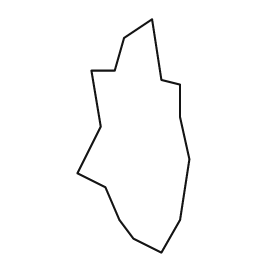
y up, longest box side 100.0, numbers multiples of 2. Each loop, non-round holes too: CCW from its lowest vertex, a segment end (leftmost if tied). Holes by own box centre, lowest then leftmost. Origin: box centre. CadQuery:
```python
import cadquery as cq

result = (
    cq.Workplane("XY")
    .moveTo(12.0, -50.0)
    .lineTo(20.0, -36.0)
    .lineTo(24.0, -10.0)
    .lineTo(20.0, 8.0)
    .lineTo(20.0, 22.0)
    .lineTo(12.0, 24.0)
    .lineTo(8.0, 50.0)
    .lineTo(-4.0, 42.0)
    .lineTo(-8.0, 28.0)
    .lineTo(-18.0, 28.0)
    .lineTo(-14.0, 4.0)
    .lineTo(-24.0, -16.0)
    .lineTo(-12.0, -22.0)
    .lineTo(-6.0, -36.0)
    .lineTo(0.0, -44.0)
    .close()
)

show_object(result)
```